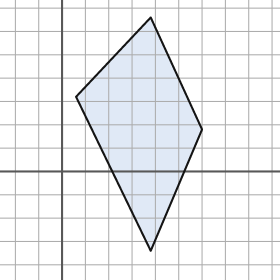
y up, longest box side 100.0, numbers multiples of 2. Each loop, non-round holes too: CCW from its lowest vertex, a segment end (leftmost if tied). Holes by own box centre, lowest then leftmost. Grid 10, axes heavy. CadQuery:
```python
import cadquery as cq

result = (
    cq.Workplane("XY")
    .moveTo(38.0, -34.0)
    .lineTo(60.0, 18.0)
    .lineTo(38.0, 66.0)
    .lineTo(6.0, 32.0)
    .close()
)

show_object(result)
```